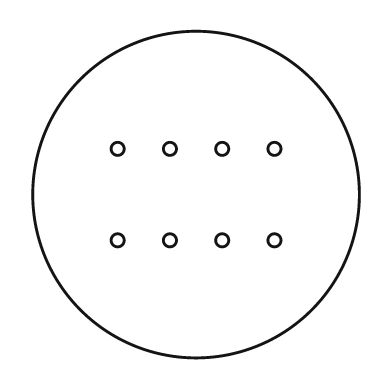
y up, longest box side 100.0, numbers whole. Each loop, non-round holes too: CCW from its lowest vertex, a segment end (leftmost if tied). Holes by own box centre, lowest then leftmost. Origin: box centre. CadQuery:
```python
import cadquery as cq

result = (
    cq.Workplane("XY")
    .moveTo(0.0, 0.0)
    .circle(50.0)
    .moveTo(-24.0, -14.0)
    .circle(2.0)
    .moveTo(-8.0, -14.0)
    .circle(2.0)
    .moveTo(8.0, -14.0)
    .circle(2.0)
    .moveTo(24.0, -14.0)
    .circle(2.0)
    .moveTo(-24.0, 14.0)
    .circle(2.0)
    .moveTo(-8.0, 14.0)
    .circle(2.0)
    .moveTo(8.0, 14.0)
    .circle(2.0)
    .moveTo(24.0, 14.0)
    .circle(2.0)
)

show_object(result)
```